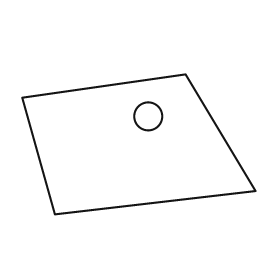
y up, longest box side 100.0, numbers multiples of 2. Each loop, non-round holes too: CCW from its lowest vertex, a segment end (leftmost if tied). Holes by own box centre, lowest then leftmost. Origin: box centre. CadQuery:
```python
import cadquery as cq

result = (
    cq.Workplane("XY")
    .moveTo(-36.0, -30.0)
    .lineTo(50.0, -20.0)
    .lineTo(20.0, 30.0)
    .lineTo(-50.0, 20.0)
    .close()
    .moveTo(4.0, 12.0)
    .circle(6.0)
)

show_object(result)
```